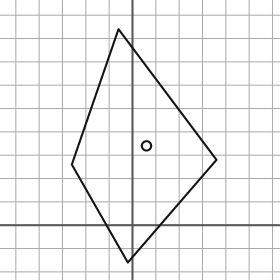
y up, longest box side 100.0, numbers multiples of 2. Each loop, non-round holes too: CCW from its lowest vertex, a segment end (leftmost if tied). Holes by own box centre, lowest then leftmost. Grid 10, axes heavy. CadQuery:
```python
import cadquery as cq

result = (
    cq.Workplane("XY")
    .moveTo(-2.0, -16.0)
    .lineTo(36.0, 28.0)
    .lineTo(-6.0, 84.0)
    .lineTo(-26.0, 26.0)
    .close()
    .moveTo(6.0, 34.0)
    .circle(2.0)
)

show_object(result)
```